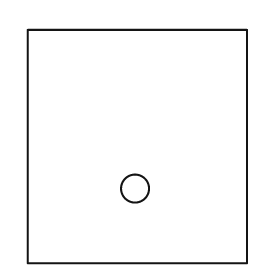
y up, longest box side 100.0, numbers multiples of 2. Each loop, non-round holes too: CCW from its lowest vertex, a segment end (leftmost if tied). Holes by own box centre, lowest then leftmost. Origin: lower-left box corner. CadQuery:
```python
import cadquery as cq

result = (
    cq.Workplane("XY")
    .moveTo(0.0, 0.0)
    .lineTo(94.0, 0.0)
    .lineTo(94.0, 100.0)
    .lineTo(0.0, 100.0)
    .close()
    .moveTo(46.0, 32.0)
    .circle(6.0)
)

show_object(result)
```